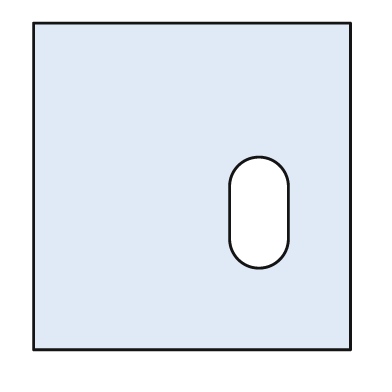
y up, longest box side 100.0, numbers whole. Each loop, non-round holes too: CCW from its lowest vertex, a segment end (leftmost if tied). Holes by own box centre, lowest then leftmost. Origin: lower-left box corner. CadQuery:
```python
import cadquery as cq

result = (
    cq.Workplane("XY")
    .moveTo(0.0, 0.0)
    .lineTo(97.0, 0.0)
    .lineTo(97.0, 100.0)
    .lineTo(0.0, 100.0)
    .close()
    .moveTo(60.0, 34.0)
    .threePointArc((69.0, 25.0), (78.0, 34.0))
    .lineTo(78.0, 50.0)
    .threePointArc((69.0, 59.0), (60.0, 50.0))
    .close()
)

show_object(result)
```